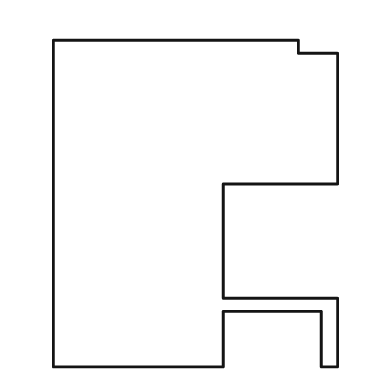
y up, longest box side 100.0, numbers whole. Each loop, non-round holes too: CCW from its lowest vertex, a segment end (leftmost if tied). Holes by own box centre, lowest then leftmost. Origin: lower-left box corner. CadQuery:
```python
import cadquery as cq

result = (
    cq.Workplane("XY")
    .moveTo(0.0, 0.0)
    .lineTo(52.0, 0.0)
    .lineTo(52.0, 17.0)
    .lineTo(82.0, 17.0)
    .lineTo(82.0, 0.0)
    .lineTo(87.0, 0.0)
    .lineTo(87.0, 21.0)
    .lineTo(52.0, 21.0)
    .lineTo(52.0, 56.0)
    .lineTo(87.0, 56.0)
    .lineTo(87.0, 96.0)
    .lineTo(75.0, 96.0)
    .lineTo(75.0, 100.0)
    .lineTo(0.0, 100.0)
    .close()
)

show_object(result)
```